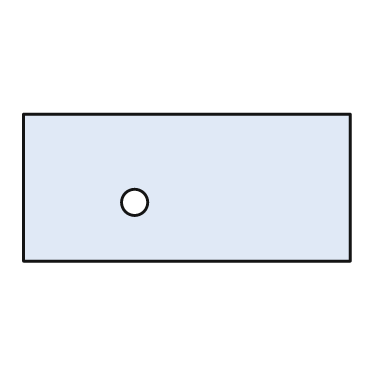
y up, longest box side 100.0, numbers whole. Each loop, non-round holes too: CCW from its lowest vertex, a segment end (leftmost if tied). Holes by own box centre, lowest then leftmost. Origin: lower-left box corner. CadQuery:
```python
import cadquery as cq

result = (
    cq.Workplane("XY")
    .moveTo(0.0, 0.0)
    .lineTo(100.0, 0.0)
    .lineTo(100.0, 45.0)
    .lineTo(0.0, 45.0)
    .close()
    .moveTo(34.0, 18.0)
    .circle(4.0)
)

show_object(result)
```